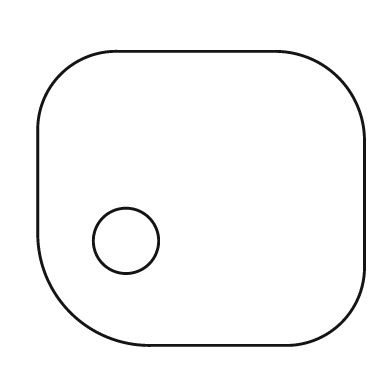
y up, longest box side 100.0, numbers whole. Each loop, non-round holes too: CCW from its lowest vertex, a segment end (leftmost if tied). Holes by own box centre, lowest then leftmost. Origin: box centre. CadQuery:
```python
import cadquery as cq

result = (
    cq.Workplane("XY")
    .moveTo(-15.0, -45.0)
    .lineTo(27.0, -45.0)
    .threePointArc((43.0, -38.0), (50.0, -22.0))
    .lineTo(50.0, 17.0)
    .threePointArc((42.0, 37.0), (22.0, 45.0))
    .lineTo(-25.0, 45.0)
    .threePointArc((-43.0, 38.0), (-50.0, 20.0))
    .lineTo(-50.0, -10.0)
    .threePointArc((-40.0, -35.0), (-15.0, -45.0))
    .close()
    .moveTo(-23.0, -13.0)
    .circle(10.0)
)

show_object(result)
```